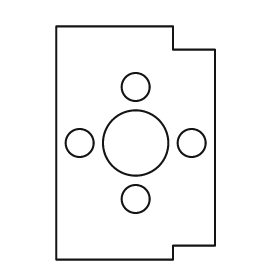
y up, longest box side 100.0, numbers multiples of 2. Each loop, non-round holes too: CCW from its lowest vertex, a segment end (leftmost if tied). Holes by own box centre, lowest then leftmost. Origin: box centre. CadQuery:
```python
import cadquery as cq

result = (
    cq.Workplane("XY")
    .moveTo(-34.0, -50.0)
    .lineTo(16.0, -50.0)
    .lineTo(16.0, -44.0)
    .lineTo(34.0, -44.0)
    .lineTo(34.0, 40.0)
    .lineTo(16.0, 40.0)
    .lineTo(16.0, 50.0)
    .lineTo(-34.0, 50.0)
    .close()
    .moveTo(0.0, -24.0)
    .circle(6.0)
    .moveTo(-24.0, 0.0)
    .circle(6.0)
    .moveTo(0.0, 0.0)
    .circle(14.0)
    .moveTo(24.0, 0.0)
    .circle(6.0)
    .moveTo(0.0, 24.0)
    .circle(6.0)
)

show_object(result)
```